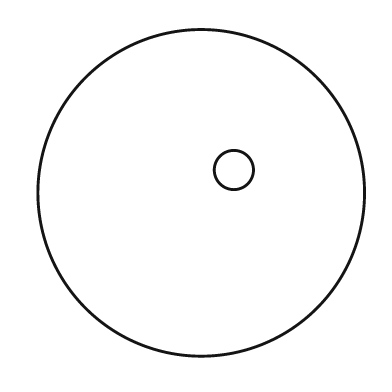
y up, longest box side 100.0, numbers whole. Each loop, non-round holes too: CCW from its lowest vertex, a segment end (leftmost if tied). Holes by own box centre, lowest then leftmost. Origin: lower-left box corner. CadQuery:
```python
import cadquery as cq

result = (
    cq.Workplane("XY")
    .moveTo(50.0, 50.0)
    .circle(50.0)
    .moveTo(60.0, 57.0)
    .circle(6.0)
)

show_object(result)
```